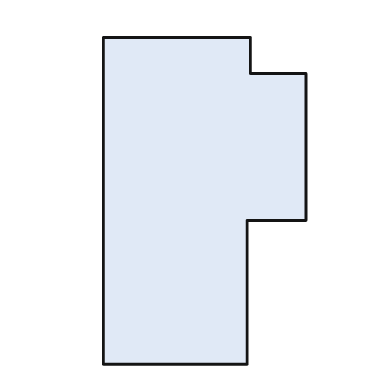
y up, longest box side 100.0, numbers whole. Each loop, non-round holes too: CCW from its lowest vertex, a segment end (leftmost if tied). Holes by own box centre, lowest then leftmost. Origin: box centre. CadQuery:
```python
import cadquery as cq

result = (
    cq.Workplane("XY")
    .moveTo(-31.0, -50.0)
    .lineTo(13.0, -50.0)
    .lineTo(13.0, -6.0)
    .lineTo(31.0, -6.0)
    .lineTo(31.0, 39.0)
    .lineTo(14.0, 39.0)
    .lineTo(14.0, 50.0)
    .lineTo(-31.0, 50.0)
    .close()
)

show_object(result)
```